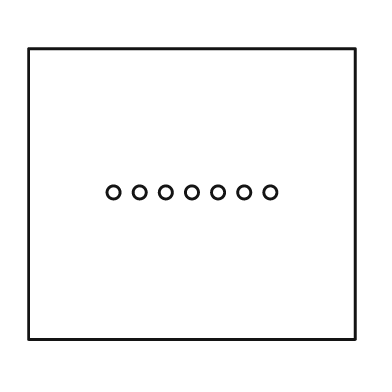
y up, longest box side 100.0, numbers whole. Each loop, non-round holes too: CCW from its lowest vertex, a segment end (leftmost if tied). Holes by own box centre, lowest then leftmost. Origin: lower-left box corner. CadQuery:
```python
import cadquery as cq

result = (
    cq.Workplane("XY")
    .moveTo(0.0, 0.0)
    .lineTo(100.0, 0.0)
    .lineTo(100.0, 89.0)
    .lineTo(0.0, 89.0)
    .close()
    .moveTo(26.0, 45.0)
    .circle(2.0)
    .moveTo(34.0, 45.0)
    .circle(2.0)
    .moveTo(42.0, 45.0)
    .circle(2.0)
    .moveTo(50.0, 45.0)
    .circle(2.0)
    .moveTo(58.0, 45.0)
    .circle(2.0)
    .moveTo(66.0, 45.0)
    .circle(2.0)
    .moveTo(74.0, 45.0)
    .circle(2.0)
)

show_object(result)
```